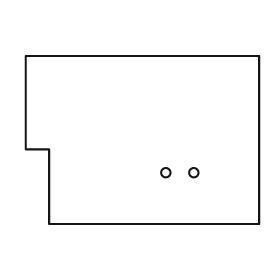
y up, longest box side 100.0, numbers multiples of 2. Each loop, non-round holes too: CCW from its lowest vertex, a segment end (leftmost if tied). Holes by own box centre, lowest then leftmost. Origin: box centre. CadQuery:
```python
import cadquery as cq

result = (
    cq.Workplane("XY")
    .moveTo(-40.0, -36.0)
    .lineTo(50.0, -36.0)
    .lineTo(50.0, 36.0)
    .lineTo(-50.0, 36.0)
    .lineTo(-50.0, -4.0)
    .lineTo(-40.0, -4.0)
    .close()
    .moveTo(10.0, -14.0)
    .circle(2.0)
    .moveTo(22.0, -14.0)
    .circle(2.0)
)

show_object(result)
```